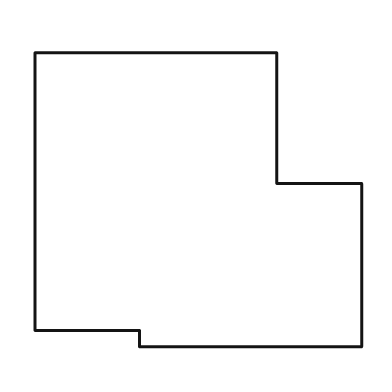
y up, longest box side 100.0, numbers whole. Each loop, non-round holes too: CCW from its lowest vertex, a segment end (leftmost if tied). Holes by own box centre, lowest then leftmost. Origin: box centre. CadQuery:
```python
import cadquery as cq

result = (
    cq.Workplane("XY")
    .moveTo(-18.0, -45.0)
    .lineTo(50.0, -45.0)
    .lineTo(50.0, 5.0)
    .lineTo(24.0, 5.0)
    .lineTo(24.0, 45.0)
    .lineTo(-50.0, 45.0)
    .lineTo(-50.0, -40.0)
    .lineTo(-18.0, -40.0)
    .close()
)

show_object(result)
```